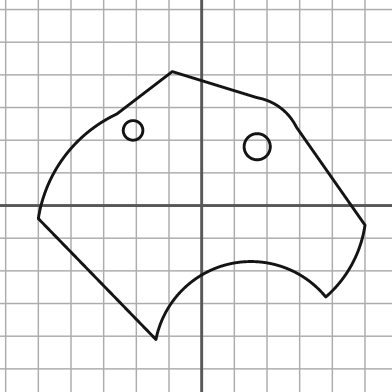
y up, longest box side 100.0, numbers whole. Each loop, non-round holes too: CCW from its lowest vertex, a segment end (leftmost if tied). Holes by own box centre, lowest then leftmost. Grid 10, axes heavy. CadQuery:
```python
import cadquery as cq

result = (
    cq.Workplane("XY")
    .moveTo(-14.0, -41.0)
    .threePointArc((8.0, -18.0), (38.0, -28.0))
    .threePointArc((46.0, -18.0), (50.0, -6.0))
    .lineTo(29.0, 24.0)
    .threePointArc((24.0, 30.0), (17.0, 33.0))
    .lineTo(-9.0, 41.0)
    .lineTo(-26.0, 28.0)
    .threePointArc((-42.0, 15.0), (-50.0, -4.0))
    .close()
    .moveTo(17.0, 18.0)
    .circle(4.0)
    .moveTo(-21.0, 23.0)
    .circle(3.0)
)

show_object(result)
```